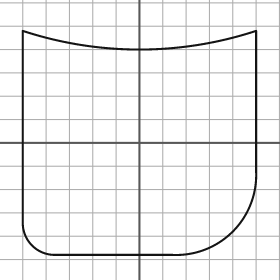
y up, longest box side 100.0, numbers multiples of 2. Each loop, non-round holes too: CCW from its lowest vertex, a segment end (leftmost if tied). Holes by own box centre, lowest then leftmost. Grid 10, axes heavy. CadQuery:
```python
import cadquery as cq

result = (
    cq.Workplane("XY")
    .moveTo(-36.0, -48.0)
    .lineTo(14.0, -48.0)
    .threePointArc((40.0, -38.0), (50.0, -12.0))
    .lineTo(50.0, 48.0)
    .threePointArc((0.0, 40.0), (-50.0, 48.0))
    .lineTo(-50.0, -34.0)
    .threePointArc((-46.0, -44.0), (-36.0, -48.0))
    .close()
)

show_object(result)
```